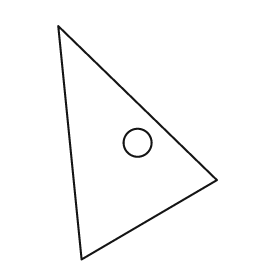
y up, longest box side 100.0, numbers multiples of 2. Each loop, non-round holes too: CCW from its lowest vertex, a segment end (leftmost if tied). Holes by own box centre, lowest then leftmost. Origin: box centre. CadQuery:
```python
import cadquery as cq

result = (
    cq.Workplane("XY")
    .moveTo(-24.0, -50.0)
    .lineTo(34.0, -16.0)
    .lineTo(-34.0, 50.0)
    .close()
    .moveTo(0.0, 0.0)
    .circle(6.0)
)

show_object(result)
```